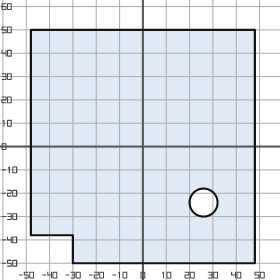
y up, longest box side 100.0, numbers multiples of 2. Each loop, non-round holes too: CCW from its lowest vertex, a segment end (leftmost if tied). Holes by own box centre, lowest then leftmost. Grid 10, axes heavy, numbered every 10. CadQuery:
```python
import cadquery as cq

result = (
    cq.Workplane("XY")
    .moveTo(-30.0, -50.0)
    .lineTo(48.0, -50.0)
    .lineTo(48.0, 50.0)
    .lineTo(-48.0, 50.0)
    .lineTo(-48.0, -38.0)
    .lineTo(-30.0, -38.0)
    .close()
    .moveTo(26.0, -24.0)
    .circle(6.0)
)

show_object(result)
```